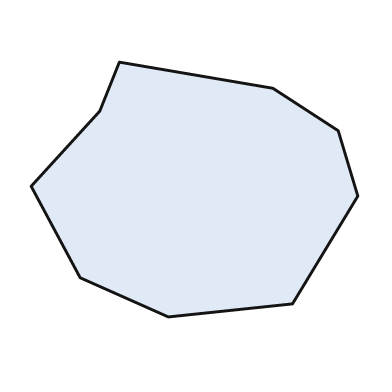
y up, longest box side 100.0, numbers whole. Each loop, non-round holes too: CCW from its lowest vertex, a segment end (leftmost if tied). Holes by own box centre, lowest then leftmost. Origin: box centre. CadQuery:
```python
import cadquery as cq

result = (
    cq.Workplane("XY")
    .moveTo(-8.0, -39.0)
    .lineTo(30.0, -35.0)
    .lineTo(50.0, -2.0)
    .lineTo(44.0, 18.0)
    .lineTo(24.0, 31.0)
    .lineTo(-23.0, 39.0)
    .lineTo(-29.0, 24.0)
    .lineTo(-50.0, 1.0)
    .lineTo(-35.0, -27.0)
    .close()
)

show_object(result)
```